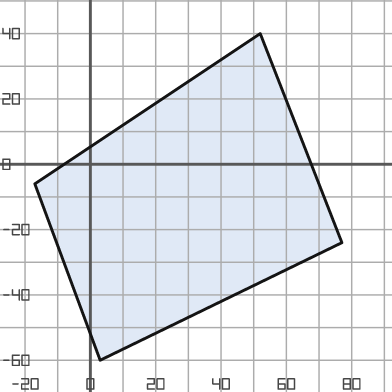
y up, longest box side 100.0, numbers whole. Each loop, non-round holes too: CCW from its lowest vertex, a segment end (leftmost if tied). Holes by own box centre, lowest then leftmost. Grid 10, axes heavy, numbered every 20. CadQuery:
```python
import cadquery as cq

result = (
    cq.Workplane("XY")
    .moveTo(3.0, -60.0)
    .lineTo(77.0, -24.0)
    .lineTo(52.0, 40.0)
    .lineTo(-17.0, -6.0)
    .close()
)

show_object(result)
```